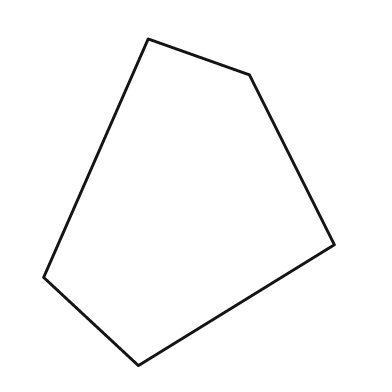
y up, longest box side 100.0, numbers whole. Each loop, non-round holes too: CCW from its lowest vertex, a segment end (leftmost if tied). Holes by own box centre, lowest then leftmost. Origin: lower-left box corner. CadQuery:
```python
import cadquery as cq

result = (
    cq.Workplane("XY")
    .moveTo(29.0, 0.0)
    .lineTo(89.0, 37.0)
    .lineTo(63.0, 89.0)
    .lineTo(32.0, 100.0)
    .lineTo(0.0, 27.0)
    .close()
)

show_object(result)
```